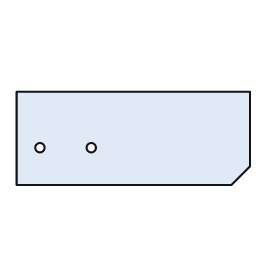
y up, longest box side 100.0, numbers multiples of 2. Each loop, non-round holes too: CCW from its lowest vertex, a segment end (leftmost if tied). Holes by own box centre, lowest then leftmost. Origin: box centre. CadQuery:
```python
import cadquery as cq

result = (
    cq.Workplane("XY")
    .moveTo(-50.0, -20.0)
    .lineTo(42.0, -20.0)
    .lineTo(50.0, -12.0)
    .lineTo(50.0, 20.0)
    .lineTo(-50.0, 20.0)
    .close()
    .moveTo(-40.0, -4.0)
    .circle(2.0)
    .moveTo(-18.0, -4.0)
    .circle(2.0)
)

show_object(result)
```